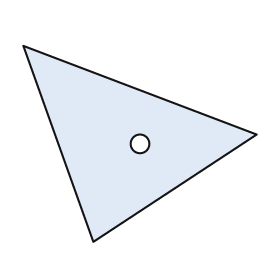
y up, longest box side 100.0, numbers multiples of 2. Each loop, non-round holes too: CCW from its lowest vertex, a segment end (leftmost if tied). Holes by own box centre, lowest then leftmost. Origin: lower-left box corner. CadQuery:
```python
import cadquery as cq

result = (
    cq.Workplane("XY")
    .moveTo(30.0, 0.0)
    .lineTo(100.0, 46.0)
    .lineTo(0.0, 84.0)
    .close()
    .moveTo(50.0, 42.0)
    .circle(4.0)
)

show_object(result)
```